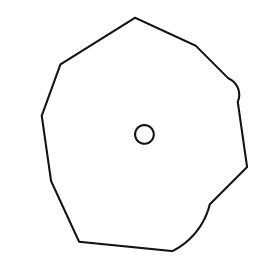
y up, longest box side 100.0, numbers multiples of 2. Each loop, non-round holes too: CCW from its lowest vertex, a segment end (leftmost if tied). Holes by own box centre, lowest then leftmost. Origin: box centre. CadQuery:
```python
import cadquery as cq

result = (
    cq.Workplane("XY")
    .moveTo(12.0, -50.0)
    .threePointArc((22.0, -42.0), (28.0, -30.0))
    .lineTo(44.0, -14.0)
    .lineTo(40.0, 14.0)
    .threePointArc((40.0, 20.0), (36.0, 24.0))
    .lineTo(22.0, 38.0)
    .lineTo(-4.0, 50.0)
    .lineTo(-36.0, 30.0)
    .lineTo(-44.0, 8.0)
    .lineTo(-40.0, -20.0)
    .lineTo(-28.0, -46.0)
    .close()
    .moveTo(0.0, 0.0)
    .circle(4.0)
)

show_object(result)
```